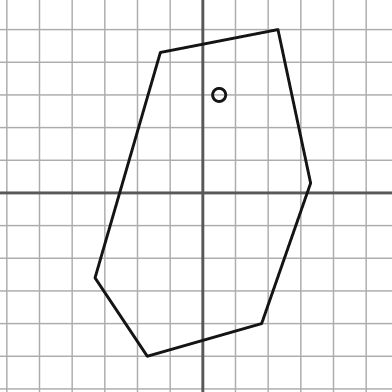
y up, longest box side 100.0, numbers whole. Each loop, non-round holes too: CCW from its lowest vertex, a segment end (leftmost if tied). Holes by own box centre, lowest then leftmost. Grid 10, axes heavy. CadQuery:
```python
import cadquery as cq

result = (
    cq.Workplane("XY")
    .moveTo(-17.0, -50.0)
    .lineTo(18.0, -40.0)
    .lineTo(33.0, 3.0)
    .lineTo(23.0, 50.0)
    .lineTo(-13.0, 43.0)
    .lineTo(-33.0, -26.0)
    .close()
    .moveTo(5.0, 30.0)
    .circle(2.0)
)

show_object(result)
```